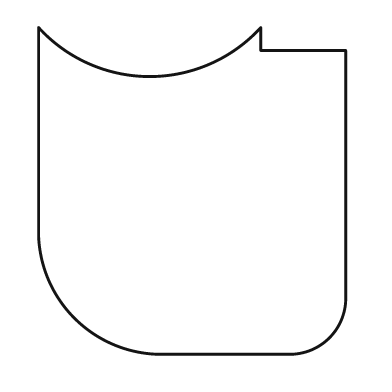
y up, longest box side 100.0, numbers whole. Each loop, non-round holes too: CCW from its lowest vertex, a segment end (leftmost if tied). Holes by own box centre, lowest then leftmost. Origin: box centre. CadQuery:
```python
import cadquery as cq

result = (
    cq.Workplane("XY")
    .moveTo(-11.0, -50.0)
    .lineTo(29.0, -50.0)
    .threePointArc((42.0, -45.0), (47.0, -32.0))
    .lineTo(47.0, 43.0)
    .lineTo(21.0, 43.0)
    .lineTo(21.0, 50.0)
    .threePointArc((-13.0, 35.0), (-47.0, 50.0))
    .lineTo(-47.0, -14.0)
    .threePointArc((-36.0, -39.0), (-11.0, -50.0))
    .close()
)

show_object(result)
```